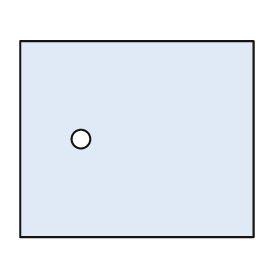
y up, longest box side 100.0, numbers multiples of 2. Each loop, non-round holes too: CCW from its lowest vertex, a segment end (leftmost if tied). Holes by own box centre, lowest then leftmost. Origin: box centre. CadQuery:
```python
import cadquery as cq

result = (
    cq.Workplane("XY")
    .moveTo(-50.0, -42.0)
    .lineTo(50.0, -42.0)
    .lineTo(50.0, 42.0)
    .lineTo(-50.0, 42.0)
    .close()
    .moveTo(-24.0, 0.0)
    .circle(4.0)
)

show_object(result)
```